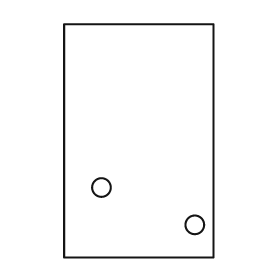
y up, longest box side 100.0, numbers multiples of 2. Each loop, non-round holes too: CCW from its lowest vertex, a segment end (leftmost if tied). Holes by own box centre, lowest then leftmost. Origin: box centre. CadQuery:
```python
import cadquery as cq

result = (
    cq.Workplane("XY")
    .moveTo(-32.0, -50.0)
    .lineTo(32.0, -50.0)
    .lineTo(32.0, 50.0)
    .lineTo(-32.0, 50.0)
    .close()
    .moveTo(24.0, -36.0)
    .circle(4.0)
    .moveTo(-16.0, -20.0)
    .circle(4.0)
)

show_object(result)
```